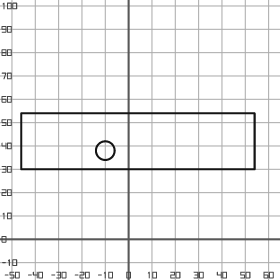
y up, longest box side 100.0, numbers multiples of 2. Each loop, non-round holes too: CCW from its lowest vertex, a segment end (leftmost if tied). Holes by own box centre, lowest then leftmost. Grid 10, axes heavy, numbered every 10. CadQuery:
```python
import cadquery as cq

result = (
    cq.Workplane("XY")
    .moveTo(-46.0, 30.0)
    .lineTo(54.0, 30.0)
    .lineTo(54.0, 54.0)
    .lineTo(-46.0, 54.0)
    .close()
    .moveTo(-10.0, 38.0)
    .circle(4.0)
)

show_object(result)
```